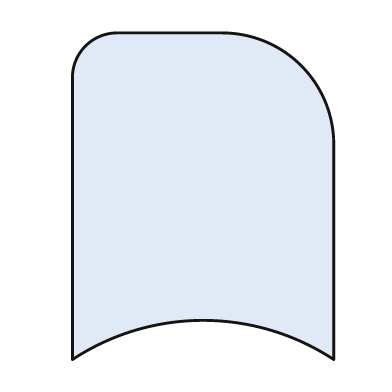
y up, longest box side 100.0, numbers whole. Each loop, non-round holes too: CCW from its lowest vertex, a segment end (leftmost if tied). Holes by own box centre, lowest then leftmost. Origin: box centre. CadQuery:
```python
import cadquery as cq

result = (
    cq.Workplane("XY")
    .moveTo(-40.0, -50.0)
    .threePointArc((0.0, -38.0), (40.0, -50.0))
    .lineTo(40.0, 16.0)
    .threePointArc((30.0, 40.0), (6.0, 50.0))
    .lineTo(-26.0, 50.0)
    .threePointArc((-36.0, 46.0), (-40.0, 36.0))
    .close()
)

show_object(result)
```